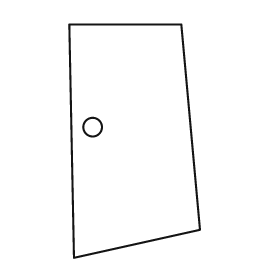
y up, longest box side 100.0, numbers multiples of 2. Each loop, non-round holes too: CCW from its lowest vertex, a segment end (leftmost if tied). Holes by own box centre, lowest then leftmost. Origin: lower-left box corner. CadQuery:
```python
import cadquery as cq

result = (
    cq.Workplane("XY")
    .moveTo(2.0, 0.0)
    .lineTo(56.0, 12.0)
    .lineTo(48.0, 100.0)
    .lineTo(0.0, 100.0)
    .close()
    .moveTo(10.0, 56.0)
    .circle(4.0)
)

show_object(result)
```